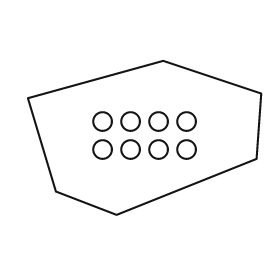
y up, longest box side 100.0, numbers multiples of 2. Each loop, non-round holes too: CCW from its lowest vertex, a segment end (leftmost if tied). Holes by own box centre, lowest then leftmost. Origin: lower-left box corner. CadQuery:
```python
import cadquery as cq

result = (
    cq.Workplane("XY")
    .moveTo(38.0, 0.0)
    .lineTo(98.0, 24.0)
    .lineTo(100.0, 52.0)
    .lineTo(58.0, 66.0)
    .lineTo(0.0, 50.0)
    .lineTo(12.0, 10.0)
    .close()
    .moveTo(32.0, 28.0)
    .circle(4.0)
    .moveTo(44.0, 28.0)
    .circle(4.0)
    .moveTo(56.0, 28.0)
    .circle(4.0)
    .moveTo(68.0, 28.0)
    .circle(4.0)
    .moveTo(32.0, 40.0)
    .circle(4.0)
    .moveTo(44.0, 40.0)
    .circle(4.0)
    .moveTo(56.0, 40.0)
    .circle(4.0)
    .moveTo(68.0, 40.0)
    .circle(4.0)
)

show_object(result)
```